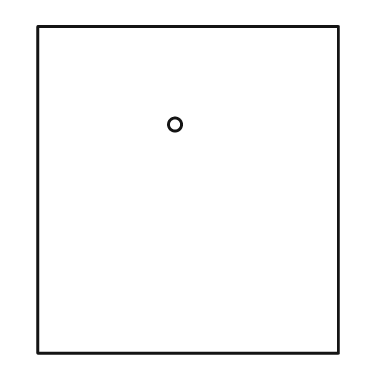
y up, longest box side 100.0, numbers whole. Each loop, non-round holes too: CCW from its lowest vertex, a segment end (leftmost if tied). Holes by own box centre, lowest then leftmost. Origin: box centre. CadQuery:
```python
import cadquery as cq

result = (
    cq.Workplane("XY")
    .moveTo(-46.0, -50.0)
    .lineTo(46.0, -50.0)
    .lineTo(46.0, 50.0)
    .lineTo(-46.0, 50.0)
    .close()
    .moveTo(-4.0, 20.0)
    .circle(2.0)
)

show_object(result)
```